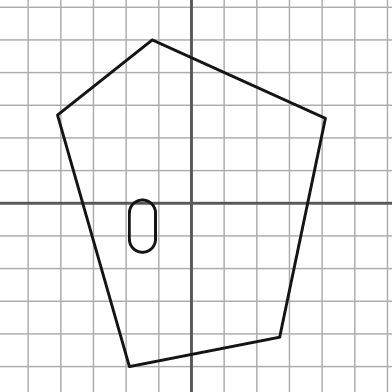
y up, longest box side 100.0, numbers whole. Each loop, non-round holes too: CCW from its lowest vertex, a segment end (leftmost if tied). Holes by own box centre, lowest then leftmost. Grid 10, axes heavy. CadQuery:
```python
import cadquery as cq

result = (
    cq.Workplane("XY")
    .moveTo(-19.0, -50.0)
    .lineTo(27.0, -41.0)
    .lineTo(41.0, 26.0)
    .lineTo(-12.0, 50.0)
    .lineTo(-41.0, 27.0)
    .close()
    .moveTo(-19.0, -11.0)
    .threePointArc((-15.0, -15.0), (-11.0, -11.0))
    .lineTo(-11.0, -3.0)
    .threePointArc((-15.0, 1.0), (-19.0, -3.0))
    .close()
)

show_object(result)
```